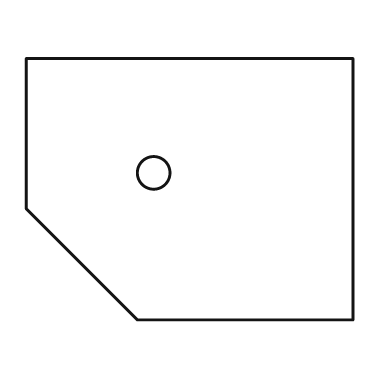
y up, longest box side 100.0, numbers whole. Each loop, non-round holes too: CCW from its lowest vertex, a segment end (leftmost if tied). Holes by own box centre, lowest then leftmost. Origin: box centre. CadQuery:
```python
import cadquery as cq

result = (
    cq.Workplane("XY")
    .moveTo(-16.0, -40.0)
    .lineTo(50.0, -40.0)
    .lineTo(50.0, 40.0)
    .lineTo(-50.0, 40.0)
    .lineTo(-50.0, -6.0)
    .close()
    .moveTo(-11.0, 5.0)
    .circle(5.0)
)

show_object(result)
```